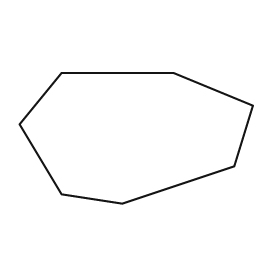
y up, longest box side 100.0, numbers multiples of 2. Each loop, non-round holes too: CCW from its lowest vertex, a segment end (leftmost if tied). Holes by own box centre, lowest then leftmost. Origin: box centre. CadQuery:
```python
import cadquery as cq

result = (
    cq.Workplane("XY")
    .moveTo(-6.0, -28.0)
    .lineTo(42.0, -12.0)
    .lineTo(50.0, 14.0)
    .lineTo(16.0, 28.0)
    .lineTo(-32.0, 28.0)
    .lineTo(-50.0, 6.0)
    .lineTo(-32.0, -24.0)
    .close()
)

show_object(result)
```